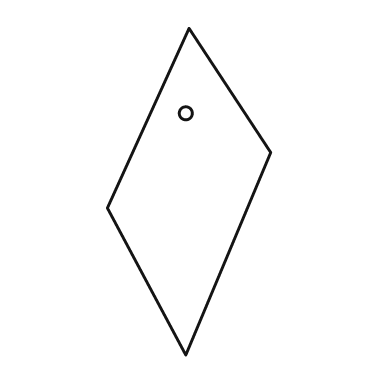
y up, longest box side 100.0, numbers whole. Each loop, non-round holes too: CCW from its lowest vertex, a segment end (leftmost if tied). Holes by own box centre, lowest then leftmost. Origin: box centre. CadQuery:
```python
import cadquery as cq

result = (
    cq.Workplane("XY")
    .moveTo(-1.0, -50.0)
    .lineTo(25.0, 12.0)
    .lineTo(0.0, 50.0)
    .lineTo(-25.0, -5.0)
    .close()
    .moveTo(-1.0, 24.0)
    .circle(2.0)
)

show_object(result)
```